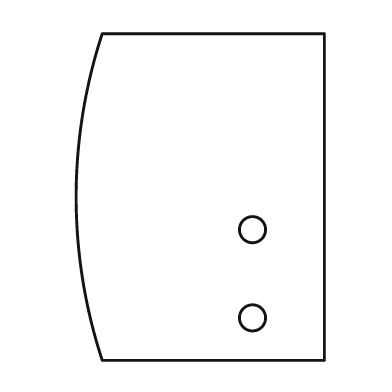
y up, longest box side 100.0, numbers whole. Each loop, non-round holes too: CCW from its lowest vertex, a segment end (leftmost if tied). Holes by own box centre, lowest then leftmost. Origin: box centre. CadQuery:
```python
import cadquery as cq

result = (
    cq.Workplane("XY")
    .moveTo(-30.0, -50.0)
    .lineTo(38.0, -50.0)
    .lineTo(38.0, 50.0)
    .lineTo(-30.0, 50.0)
    .threePointArc((-38.0, 0.0), (-30.0, -50.0))
    .close()
    .moveTo(16.0, -37.0)
    .circle(4.0)
    .moveTo(16.0, -10.0)
    .circle(4.0)
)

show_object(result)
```